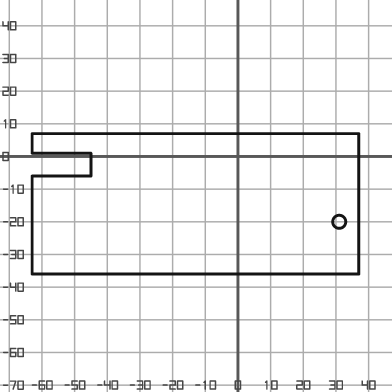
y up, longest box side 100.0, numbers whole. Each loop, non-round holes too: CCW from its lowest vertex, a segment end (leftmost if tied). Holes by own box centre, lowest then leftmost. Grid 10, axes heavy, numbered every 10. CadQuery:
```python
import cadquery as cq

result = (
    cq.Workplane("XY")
    .moveTo(-63.0, -36.0)
    .lineTo(37.0, -36.0)
    .lineTo(37.0, 7.0)
    .lineTo(-63.0, 7.0)
    .lineTo(-63.0, 1.0)
    .lineTo(-45.0, 1.0)
    .lineTo(-45.0, -6.0)
    .lineTo(-63.0, -6.0)
    .close()
    .moveTo(31.0, -20.0)
    .circle(2.0)
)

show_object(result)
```